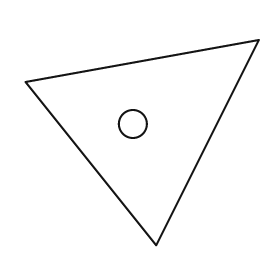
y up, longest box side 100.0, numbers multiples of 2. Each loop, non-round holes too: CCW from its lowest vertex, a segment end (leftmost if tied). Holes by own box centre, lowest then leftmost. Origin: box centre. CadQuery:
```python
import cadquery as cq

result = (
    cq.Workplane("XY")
    .moveTo(6.0, -44.0)
    .lineTo(50.0, 44.0)
    .lineTo(-50.0, 26.0)
    .close()
    .moveTo(-4.0, 8.0)
    .circle(6.0)
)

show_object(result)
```